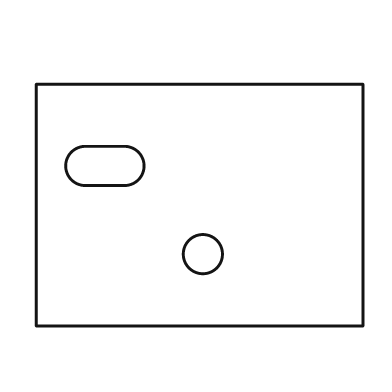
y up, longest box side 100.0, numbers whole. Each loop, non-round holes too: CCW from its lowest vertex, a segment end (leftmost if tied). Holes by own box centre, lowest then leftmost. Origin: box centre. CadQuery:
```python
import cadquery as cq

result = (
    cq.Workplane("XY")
    .moveTo(-50.0, -37.0)
    .lineTo(50.0, -37.0)
    .lineTo(50.0, 37.0)
    .lineTo(-50.0, 37.0)
    .close()
    .moveTo(1.0, -15.0)
    .circle(6.0)
    .moveTo(-35.0, 6.0)
    .lineTo(-23.0, 6.0)
    .threePointArc((-17.0, 12.0), (-23.0, 18.0))
    .lineTo(-35.0, 18.0)
    .threePointArc((-41.0, 12.0), (-35.0, 6.0))
    .close()
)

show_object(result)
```